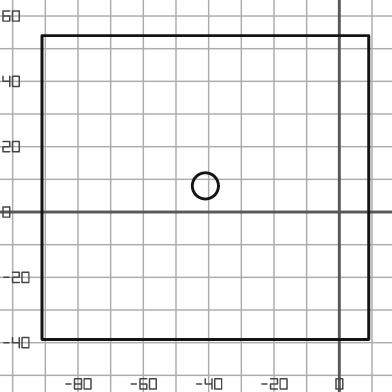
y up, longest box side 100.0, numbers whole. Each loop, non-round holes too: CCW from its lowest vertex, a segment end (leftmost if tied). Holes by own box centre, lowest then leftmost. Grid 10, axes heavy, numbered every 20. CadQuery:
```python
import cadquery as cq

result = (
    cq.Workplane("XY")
    .moveTo(-91.0, -39.0)
    .lineTo(9.0, -39.0)
    .lineTo(9.0, 54.0)
    .lineTo(-91.0, 54.0)
    .close()
    .moveTo(-41.0, 8.0)
    .circle(4.0)
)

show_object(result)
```